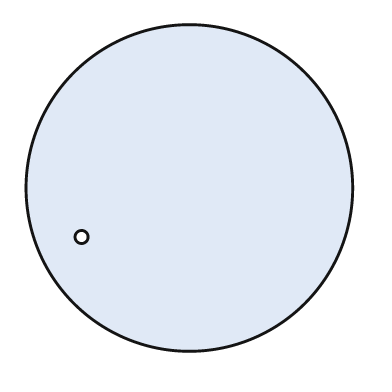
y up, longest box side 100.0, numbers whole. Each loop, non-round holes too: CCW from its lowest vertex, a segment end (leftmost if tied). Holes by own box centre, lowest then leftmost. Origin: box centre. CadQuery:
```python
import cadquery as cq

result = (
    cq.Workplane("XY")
    .moveTo(0.0, 0.0)
    .circle(50.0)
    .moveTo(-33.0, -15.0)
    .circle(2.0)
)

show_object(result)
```